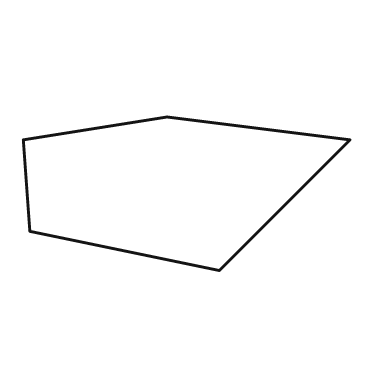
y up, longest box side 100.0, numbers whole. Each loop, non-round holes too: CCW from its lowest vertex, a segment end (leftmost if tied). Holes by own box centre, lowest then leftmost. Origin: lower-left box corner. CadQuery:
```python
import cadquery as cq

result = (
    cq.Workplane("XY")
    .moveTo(60.0, 0.0)
    .lineTo(100.0, 40.0)
    .lineTo(44.0, 47.0)
    .lineTo(0.0, 40.0)
    .lineTo(2.0, 12.0)
    .close()
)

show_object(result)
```